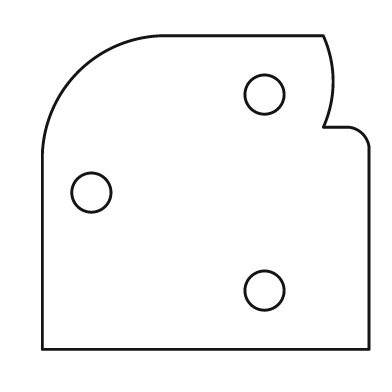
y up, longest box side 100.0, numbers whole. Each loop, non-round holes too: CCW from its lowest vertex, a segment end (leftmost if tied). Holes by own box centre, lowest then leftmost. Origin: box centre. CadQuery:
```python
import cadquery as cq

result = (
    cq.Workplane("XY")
    .moveTo(-50.0, -48.0)
    .lineTo(50.0, -48.0)
    .lineTo(50.0, 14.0)
    .threePointArc((48.0, 18.0), (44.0, 20.0))
    .lineTo(36.0, 20.0)
    .threePointArc((39.0, 34.0), (36.0, 48.0))
    .lineTo(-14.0, 48.0)
    .threePointArc((-39.0, 37.0), (-50.0, 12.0))
    .close()
    .moveTo(18.0, -30.0)
    .circle(6.0)
    .moveTo(-35.0, 0.0)
    .circle(6.0)
    .moveTo(18.0, 30.0)
    .circle(6.0)
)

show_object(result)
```